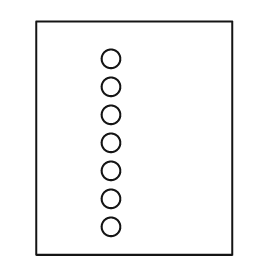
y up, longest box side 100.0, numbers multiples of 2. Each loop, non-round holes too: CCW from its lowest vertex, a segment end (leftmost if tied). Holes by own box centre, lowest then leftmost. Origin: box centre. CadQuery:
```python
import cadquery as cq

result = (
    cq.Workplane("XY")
    .moveTo(-42.0, -50.0)
    .lineTo(42.0, -50.0)
    .lineTo(42.0, 50.0)
    .lineTo(-42.0, 50.0)
    .close()
    .moveTo(-10.0, -38.0)
    .circle(4.0)
    .moveTo(-10.0, -26.0)
    .circle(4.0)
    .moveTo(-10.0, -14.0)
    .circle(4.0)
    .moveTo(-10.0, -2.0)
    .circle(4.0)
    .moveTo(-10.0, 10.0)
    .circle(4.0)
    .moveTo(-10.0, 22.0)
    .circle(4.0)
    .moveTo(-10.0, 34.0)
    .circle(4.0)
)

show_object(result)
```